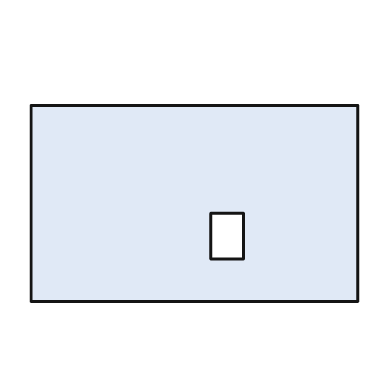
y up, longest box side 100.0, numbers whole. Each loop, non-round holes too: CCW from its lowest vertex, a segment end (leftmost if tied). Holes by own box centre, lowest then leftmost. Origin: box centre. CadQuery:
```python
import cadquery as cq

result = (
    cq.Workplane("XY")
    .moveTo(-50.0, -30.0)
    .lineTo(50.0, -30.0)
    .lineTo(50.0, 30.0)
    .lineTo(-50.0, 30.0)
    .close()
    .moveTo(5.0, -17.0)
    .lineTo(15.0, -17.0)
    .lineTo(15.0, -3.0)
    .lineTo(5.0, -3.0)
    .close()
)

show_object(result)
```